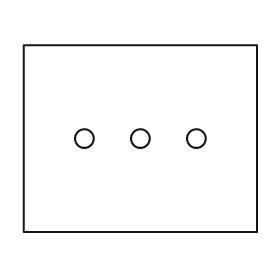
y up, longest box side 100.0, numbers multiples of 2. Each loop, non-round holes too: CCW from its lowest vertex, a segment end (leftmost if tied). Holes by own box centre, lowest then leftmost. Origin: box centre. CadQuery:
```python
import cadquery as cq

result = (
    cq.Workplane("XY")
    .moveTo(-50.0, -40.0)
    .lineTo(50.0, -40.0)
    .lineTo(50.0, 40.0)
    .lineTo(-50.0, 40.0)
    .close()
    .moveTo(-24.0, 0.0)
    .circle(4.0)
    .moveTo(0.0, 0.0)
    .circle(4.0)
    .moveTo(24.0, 0.0)
    .circle(4.0)
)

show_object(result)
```